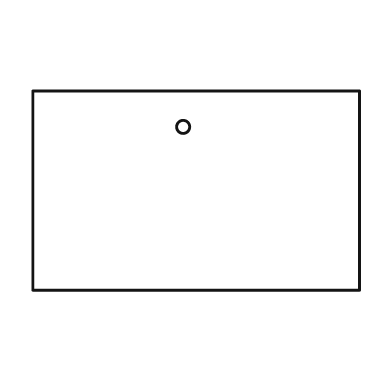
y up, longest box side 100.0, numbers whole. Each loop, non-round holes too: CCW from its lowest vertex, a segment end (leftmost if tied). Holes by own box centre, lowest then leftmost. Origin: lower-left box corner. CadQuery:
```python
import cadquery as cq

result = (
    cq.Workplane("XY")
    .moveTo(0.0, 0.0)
    .lineTo(100.0, 0.0)
    .lineTo(100.0, 61.0)
    .lineTo(0.0, 61.0)
    .close()
    .moveTo(46.0, 50.0)
    .circle(2.0)
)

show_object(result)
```